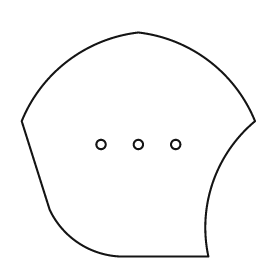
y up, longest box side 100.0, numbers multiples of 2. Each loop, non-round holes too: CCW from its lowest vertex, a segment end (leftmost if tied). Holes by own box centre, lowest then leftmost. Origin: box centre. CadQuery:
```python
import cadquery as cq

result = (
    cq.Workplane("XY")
    .moveTo(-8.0, -48.0)
    .lineTo(30.0, -48.0)
    .threePointArc((32.0, -16.0), (50.0, 10.0))
    .threePointArc((30.0, 36.0), (0.0, 48.0))
    .threePointArc((-30.0, 36.0), (-50.0, 10.0))
    .lineTo(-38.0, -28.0)
    .threePointArc((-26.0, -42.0), (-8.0, -48.0))
    .close()
    .moveTo(-16.0, 0.0)
    .circle(2.0)
    .moveTo(0.0, 0.0)
    .circle(2.0)
    .moveTo(16.0, 0.0)
    .circle(2.0)
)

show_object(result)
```